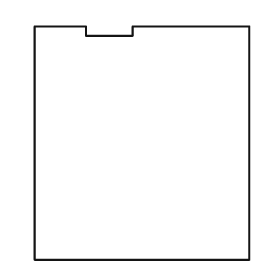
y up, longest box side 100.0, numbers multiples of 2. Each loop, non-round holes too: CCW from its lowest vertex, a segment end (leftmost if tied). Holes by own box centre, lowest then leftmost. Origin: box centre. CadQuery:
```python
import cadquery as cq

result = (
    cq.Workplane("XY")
    .moveTo(-46.0, -50.0)
    .lineTo(46.0, -50.0)
    .lineTo(46.0, 50.0)
    .lineTo(-4.0, 50.0)
    .lineTo(-4.0, 46.0)
    .lineTo(-24.0, 46.0)
    .lineTo(-24.0, 50.0)
    .lineTo(-46.0, 50.0)
    .close()
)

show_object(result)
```